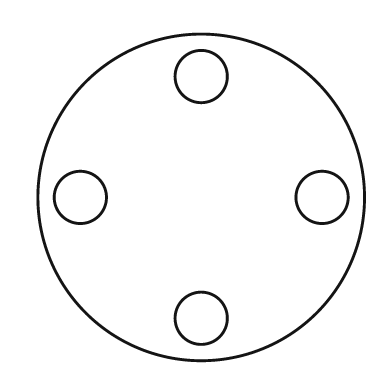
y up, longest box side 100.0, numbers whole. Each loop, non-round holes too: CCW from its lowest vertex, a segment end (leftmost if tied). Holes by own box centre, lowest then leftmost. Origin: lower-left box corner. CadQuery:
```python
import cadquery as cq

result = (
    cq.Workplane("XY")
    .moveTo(50.0, 50.0)
    .circle(50.0)
    .moveTo(50.0, 13.0)
    .circle(8.0)
    .moveTo(13.0, 50.0)
    .circle(8.0)
    .moveTo(87.0, 50.0)
    .circle(8.0)
    .moveTo(50.0, 87.0)
    .circle(8.0)
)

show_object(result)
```